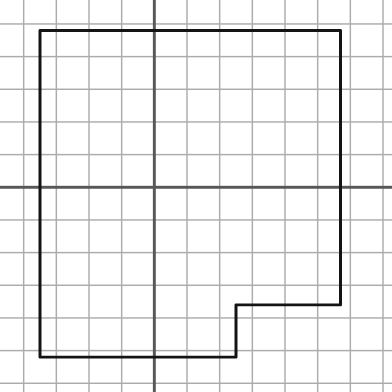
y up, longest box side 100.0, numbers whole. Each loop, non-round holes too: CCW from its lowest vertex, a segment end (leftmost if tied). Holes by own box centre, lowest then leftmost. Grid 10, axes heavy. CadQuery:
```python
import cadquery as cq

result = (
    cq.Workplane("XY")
    .moveTo(-35.0, -52.0)
    .lineTo(25.0, -52.0)
    .lineTo(25.0, -36.0)
    .lineTo(57.0, -36.0)
    .lineTo(57.0, 48.0)
    .lineTo(-35.0, 48.0)
    .close()
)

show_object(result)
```